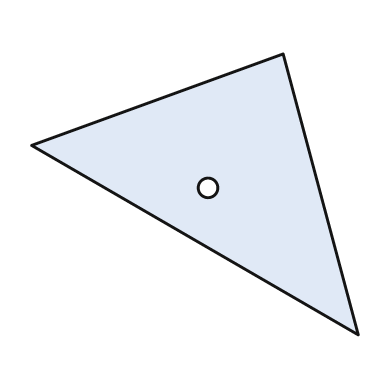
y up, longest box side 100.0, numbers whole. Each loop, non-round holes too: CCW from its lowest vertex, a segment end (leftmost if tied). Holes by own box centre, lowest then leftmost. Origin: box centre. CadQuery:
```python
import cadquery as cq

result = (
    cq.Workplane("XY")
    .moveTo(50.0, -43.0)
    .lineTo(27.0, 43.0)
    .lineTo(-50.0, 15.0)
    .close()
    .moveTo(4.0, 2.0)
    .circle(3.0)
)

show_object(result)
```